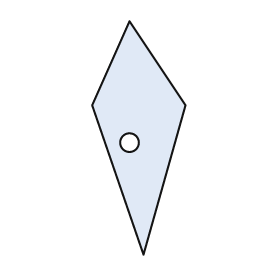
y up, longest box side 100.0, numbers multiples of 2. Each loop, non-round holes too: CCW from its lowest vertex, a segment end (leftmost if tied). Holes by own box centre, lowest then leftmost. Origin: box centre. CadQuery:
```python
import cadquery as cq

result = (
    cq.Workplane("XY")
    .moveTo(2.0, -50.0)
    .lineTo(20.0, 14.0)
    .lineTo(-4.0, 50.0)
    .lineTo(-20.0, 14.0)
    .close()
    .moveTo(-4.0, -2.0)
    .circle(4.0)
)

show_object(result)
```